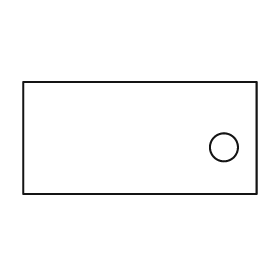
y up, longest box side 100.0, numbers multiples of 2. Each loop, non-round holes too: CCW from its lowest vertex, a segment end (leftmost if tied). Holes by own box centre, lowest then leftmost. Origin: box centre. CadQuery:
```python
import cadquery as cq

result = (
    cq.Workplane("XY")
    .moveTo(-50.0, -24.0)
    .lineTo(50.0, -24.0)
    .lineTo(50.0, 24.0)
    .lineTo(-50.0, 24.0)
    .close()
    .moveTo(36.0, -4.0)
    .circle(6.0)
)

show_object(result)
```